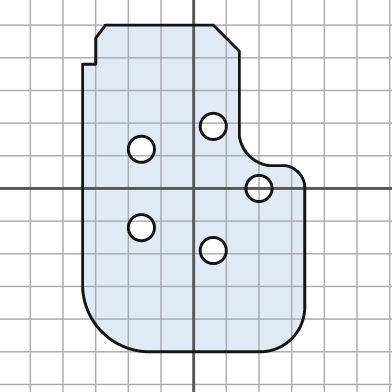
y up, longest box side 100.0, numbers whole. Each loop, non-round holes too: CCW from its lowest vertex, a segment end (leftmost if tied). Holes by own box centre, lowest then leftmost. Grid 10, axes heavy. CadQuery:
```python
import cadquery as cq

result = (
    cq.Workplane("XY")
    .moveTo(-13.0, -50.0)
    .lineTo(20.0, -50.0)
    .threePointArc((30.0, -46.0), (34.0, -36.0))
    .lineTo(34.0, 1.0)
    .threePointArc((32.0, 5.0), (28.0, 7.0))
    .lineTo(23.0, 7.0)
    .threePointArc((17.0, 10.0), (14.0, 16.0))
    .lineTo(14.0, 42.0)
    .lineTo(6.0, 50.0)
    .lineTo(-27.0, 50.0)
    .lineTo(-30.0, 46.0)
    .lineTo(-30.0, 38.0)
    .lineTo(-34.0, 38.0)
    .lineTo(-34.0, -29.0)
    .threePointArc((-28.0, -44.0), (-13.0, -50.0))
    .close()
    .moveTo(6.0, -19.0)
    .circle(4.0)
    .moveTo(-16.0, -12.0)
    .circle(4.0)
    .moveTo(20.0, 0.0)
    .circle(4.0)
    .moveTo(-16.0, 12.0)
    .circle(4.0)
    .moveTo(6.0, 19.0)
    .circle(4.0)
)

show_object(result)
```